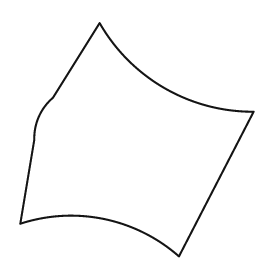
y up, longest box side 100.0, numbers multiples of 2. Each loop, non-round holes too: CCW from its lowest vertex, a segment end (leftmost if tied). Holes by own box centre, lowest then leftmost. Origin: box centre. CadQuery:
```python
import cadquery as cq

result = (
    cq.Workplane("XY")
    .moveTo(18.0, -50.0)
    .lineTo(50.0, 12.0)
    .threePointArc((12.0, 22.0), (-16.0, 50.0))
    .lineTo(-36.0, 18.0)
    .threePointArc((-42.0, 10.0), (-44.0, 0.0))
    .lineTo(-50.0, -36.0)
    .threePointArc((-14.0, -34.0), (18.0, -50.0))
    .close()
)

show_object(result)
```